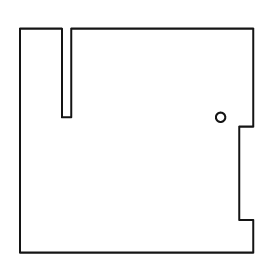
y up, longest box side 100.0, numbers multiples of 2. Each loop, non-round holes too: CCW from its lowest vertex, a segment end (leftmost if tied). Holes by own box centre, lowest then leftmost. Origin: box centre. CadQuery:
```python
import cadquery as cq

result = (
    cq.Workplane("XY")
    .moveTo(-50.0, -48.0)
    .lineTo(50.0, -48.0)
    .lineTo(50.0, -34.0)
    .lineTo(44.0, -34.0)
    .lineTo(44.0, 6.0)
    .lineTo(50.0, 6.0)
    .lineTo(50.0, 48.0)
    .lineTo(-28.0, 48.0)
    .lineTo(-28.0, 10.0)
    .lineTo(-32.0, 10.0)
    .lineTo(-32.0, 48.0)
    .lineTo(-50.0, 48.0)
    .close()
    .moveTo(36.0, 10.0)
    .circle(2.0)
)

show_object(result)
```